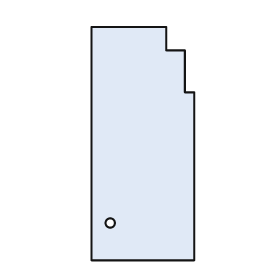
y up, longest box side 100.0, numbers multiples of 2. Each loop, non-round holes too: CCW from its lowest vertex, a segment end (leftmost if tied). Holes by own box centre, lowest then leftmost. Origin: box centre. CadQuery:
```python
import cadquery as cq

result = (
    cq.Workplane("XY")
    .moveTo(-22.0, -50.0)
    .lineTo(22.0, -50.0)
    .lineTo(22.0, 22.0)
    .lineTo(18.0, 22.0)
    .lineTo(18.0, 40.0)
    .lineTo(10.0, 40.0)
    .lineTo(10.0, 50.0)
    .lineTo(-22.0, 50.0)
    .close()
    .moveTo(-14.0, -34.0)
    .circle(2.0)
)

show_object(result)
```